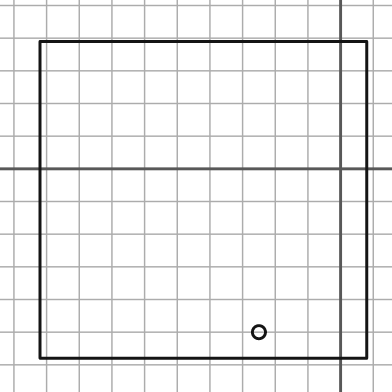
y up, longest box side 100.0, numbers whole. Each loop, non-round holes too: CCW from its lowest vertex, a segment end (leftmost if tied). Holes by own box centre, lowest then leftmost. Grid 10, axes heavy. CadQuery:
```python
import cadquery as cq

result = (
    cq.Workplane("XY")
    .moveTo(-92.0, -58.0)
    .lineTo(8.0, -58.0)
    .lineTo(8.0, 39.0)
    .lineTo(-92.0, 39.0)
    .close()
    .moveTo(-25.0, -50.0)
    .circle(2.0)
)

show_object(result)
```